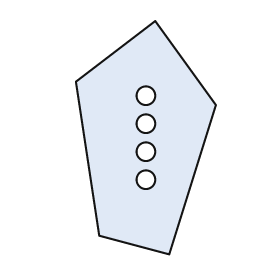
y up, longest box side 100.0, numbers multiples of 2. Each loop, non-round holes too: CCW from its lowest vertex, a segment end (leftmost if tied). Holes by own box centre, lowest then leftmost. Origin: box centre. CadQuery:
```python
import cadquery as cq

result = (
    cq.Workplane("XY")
    .moveTo(10.0, -50.0)
    .lineTo(30.0, 14.0)
    .lineTo(4.0, 50.0)
    .lineTo(-30.0, 24.0)
    .lineTo(-20.0, -42.0)
    .close()
    .moveTo(0.0, -18.0)
    .circle(4.0)
    .moveTo(0.0, -6.0)
    .circle(4.0)
    .moveTo(0.0, 6.0)
    .circle(4.0)
    .moveTo(0.0, 18.0)
    .circle(4.0)
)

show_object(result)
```